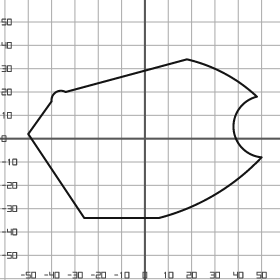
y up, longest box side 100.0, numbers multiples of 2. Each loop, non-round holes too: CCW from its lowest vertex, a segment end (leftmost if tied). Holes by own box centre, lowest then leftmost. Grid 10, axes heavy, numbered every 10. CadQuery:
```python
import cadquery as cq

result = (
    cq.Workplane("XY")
    .moveTo(-26.0, -34.0)
    .lineTo(6.0, -34.0)
    .threePointArc((30.0, -24.0), (50.0, -8.0))
    .threePointArc((38.0, 4.0), (48.0, 18.0))
    .threePointArc((34.0, 28.0), (18.0, 34.0))
    .lineTo(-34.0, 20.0)
    .threePointArc((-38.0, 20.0), (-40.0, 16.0))
    .lineTo(-50.0, 2.0)
    .close()
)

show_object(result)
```